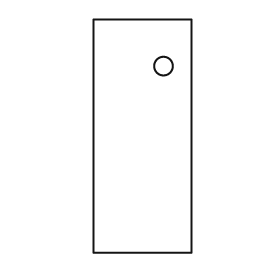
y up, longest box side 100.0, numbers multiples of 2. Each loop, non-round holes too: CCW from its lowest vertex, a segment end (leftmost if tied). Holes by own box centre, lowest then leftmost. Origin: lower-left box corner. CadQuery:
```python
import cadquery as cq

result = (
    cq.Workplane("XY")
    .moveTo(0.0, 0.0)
    .lineTo(42.0, 0.0)
    .lineTo(42.0, 100.0)
    .lineTo(0.0, 100.0)
    .close()
    .moveTo(30.0, 80.0)
    .circle(4.0)
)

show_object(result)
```